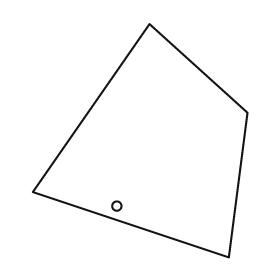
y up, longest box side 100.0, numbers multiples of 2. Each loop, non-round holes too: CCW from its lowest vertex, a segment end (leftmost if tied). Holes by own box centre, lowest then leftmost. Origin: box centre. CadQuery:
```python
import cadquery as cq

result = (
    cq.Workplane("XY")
    .moveTo(38.0, -50.0)
    .lineTo(46.0, 12.0)
    .lineTo(4.0, 50.0)
    .lineTo(-46.0, -22.0)
    .close()
    .moveTo(-10.0, -28.0)
    .circle(2.0)
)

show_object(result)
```